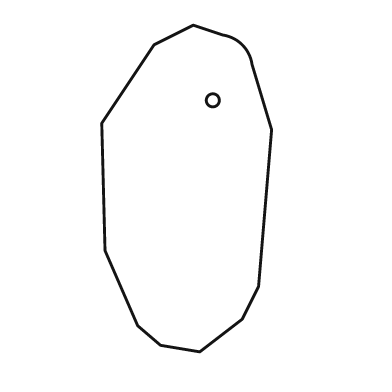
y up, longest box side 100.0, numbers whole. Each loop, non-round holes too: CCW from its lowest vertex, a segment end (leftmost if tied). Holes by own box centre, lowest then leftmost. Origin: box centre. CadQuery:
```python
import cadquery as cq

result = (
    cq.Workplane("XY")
    .moveTo(4.0, -50.0)
    .lineTo(17.0, -40.0)
    .lineTo(22.0, -30.0)
    .lineTo(26.0, 18.0)
    .lineTo(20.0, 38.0)
    .threePointArc((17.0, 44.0), (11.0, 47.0))
    .lineTo(2.0, 50.0)
    .lineTo(-10.0, 44.0)
    .lineTo(-26.0, 20.0)
    .lineTo(-25.0, -19.0)
    .lineTo(-15.0, -42.0)
    .lineTo(-8.0, -48.0)
    .close()
    .moveTo(8.0, 27.0)
    .circle(2.0)
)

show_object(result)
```